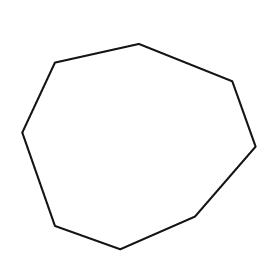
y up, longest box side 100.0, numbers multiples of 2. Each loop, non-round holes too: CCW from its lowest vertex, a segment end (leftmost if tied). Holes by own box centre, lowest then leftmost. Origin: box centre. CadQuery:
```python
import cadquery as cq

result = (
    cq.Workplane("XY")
    .moveTo(-8.0, -44.0)
    .lineTo(24.0, -30.0)
    .lineTo(50.0, 0.0)
    .lineTo(40.0, 28.0)
    .lineTo(0.0, 44.0)
    .lineTo(-36.0, 36.0)
    .lineTo(-50.0, 6.0)
    .lineTo(-36.0, -34.0)
    .close()
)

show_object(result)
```